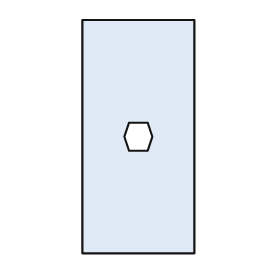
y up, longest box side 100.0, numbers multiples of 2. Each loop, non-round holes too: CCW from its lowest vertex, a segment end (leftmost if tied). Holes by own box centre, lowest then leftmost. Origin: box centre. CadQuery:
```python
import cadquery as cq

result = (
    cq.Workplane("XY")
    .moveTo(-24.0, -50.0)
    .lineTo(24.0, -50.0)
    .lineTo(24.0, 50.0)
    .lineTo(-24.0, 50.0)
    .close()
    .moveTo(-4.0, -6.0)
    .lineTo(4.0, -6.0)
    .lineTo(6.0, 0.0)
    .lineTo(4.0, 6.0)
    .lineTo(-4.0, 6.0)
    .lineTo(-6.0, 0.0)
    .close()
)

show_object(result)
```